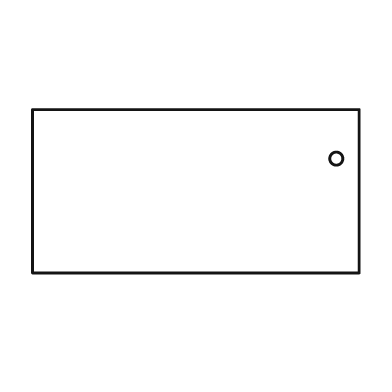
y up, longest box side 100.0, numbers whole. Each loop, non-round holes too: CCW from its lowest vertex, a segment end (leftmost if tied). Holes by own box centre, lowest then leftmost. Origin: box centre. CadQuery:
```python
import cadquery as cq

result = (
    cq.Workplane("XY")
    .moveTo(-50.0, -25.0)
    .lineTo(50.0, -25.0)
    .lineTo(50.0, 25.0)
    .lineTo(-50.0, 25.0)
    .close()
    .moveTo(43.0, 10.0)
    .circle(2.0)
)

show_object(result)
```